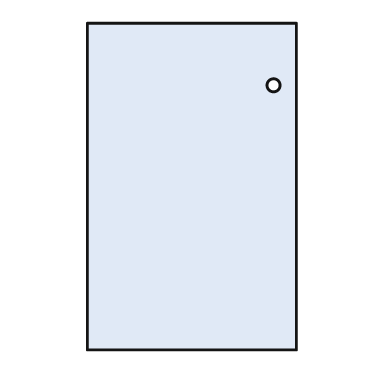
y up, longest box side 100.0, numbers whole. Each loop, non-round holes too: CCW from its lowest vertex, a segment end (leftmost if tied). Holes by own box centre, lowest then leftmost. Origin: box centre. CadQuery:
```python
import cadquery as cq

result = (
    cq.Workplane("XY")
    .moveTo(-32.0, -50.0)
    .lineTo(32.0, -50.0)
    .lineTo(32.0, 50.0)
    .lineTo(-32.0, 50.0)
    .close()
    .moveTo(25.0, 31.0)
    .circle(2.0)
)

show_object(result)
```